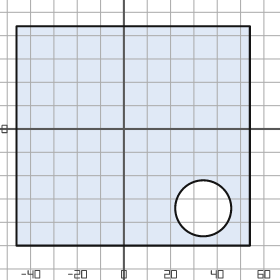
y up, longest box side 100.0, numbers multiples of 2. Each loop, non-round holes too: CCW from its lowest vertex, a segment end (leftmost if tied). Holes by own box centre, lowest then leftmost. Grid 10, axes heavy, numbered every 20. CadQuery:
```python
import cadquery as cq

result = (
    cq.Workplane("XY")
    .moveTo(-46.0, -50.0)
    .lineTo(54.0, -50.0)
    .lineTo(54.0, 44.0)
    .lineTo(-46.0, 44.0)
    .close()
    .moveTo(34.0, -34.0)
    .circle(12.0)
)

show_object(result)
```